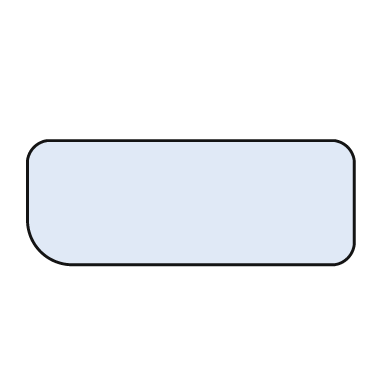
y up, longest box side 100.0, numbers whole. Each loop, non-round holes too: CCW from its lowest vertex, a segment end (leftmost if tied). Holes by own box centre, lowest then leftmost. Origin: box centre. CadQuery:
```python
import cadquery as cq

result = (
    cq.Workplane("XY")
    .moveTo(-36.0, -19.0)
    .lineTo(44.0, -19.0)
    .threePointArc((48.0, -17.0), (50.0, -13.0))
    .lineTo(50.0, 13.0)
    .threePointArc((48.0, 17.0), (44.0, 19.0))
    .lineTo(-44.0, 19.0)
    .threePointArc((-48.0, 17.0), (-50.0, 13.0))
    .lineTo(-50.0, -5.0)
    .threePointArc((-46.0, -15.0), (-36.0, -19.0))
    .close()
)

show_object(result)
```